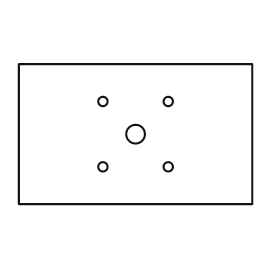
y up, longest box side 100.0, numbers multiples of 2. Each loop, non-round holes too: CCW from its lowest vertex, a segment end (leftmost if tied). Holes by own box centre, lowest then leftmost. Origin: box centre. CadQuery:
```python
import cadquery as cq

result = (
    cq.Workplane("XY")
    .moveTo(-50.0, -30.0)
    .lineTo(50.0, -30.0)
    .lineTo(50.0, 30.0)
    .lineTo(-50.0, 30.0)
    .close()
    .moveTo(-14.0, -14.0)
    .circle(2.0)
    .moveTo(14.0, -14.0)
    .circle(2.0)
    .moveTo(0.0, 0.0)
    .circle(4.0)
    .moveTo(-14.0, 14.0)
    .circle(2.0)
    .moveTo(14.0, 14.0)
    .circle(2.0)
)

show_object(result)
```